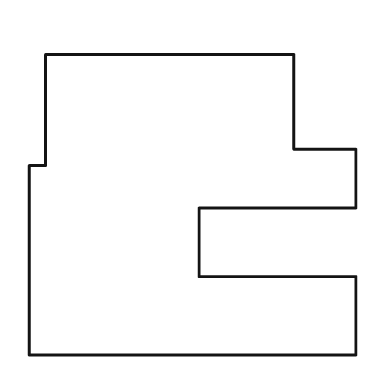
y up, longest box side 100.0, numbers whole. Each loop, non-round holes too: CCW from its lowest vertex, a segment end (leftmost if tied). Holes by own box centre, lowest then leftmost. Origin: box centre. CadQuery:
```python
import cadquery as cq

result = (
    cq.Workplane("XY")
    .moveTo(-50.0, -46.0)
    .lineTo(50.0, -46.0)
    .lineTo(50.0, -22.0)
    .lineTo(2.0, -22.0)
    .lineTo(2.0, -1.0)
    .lineTo(50.0, -1.0)
    .lineTo(50.0, 17.0)
    .lineTo(31.0, 17.0)
    .lineTo(31.0, 46.0)
    .lineTo(-45.0, 46.0)
    .lineTo(-45.0, 12.0)
    .lineTo(-50.0, 12.0)
    .close()
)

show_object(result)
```